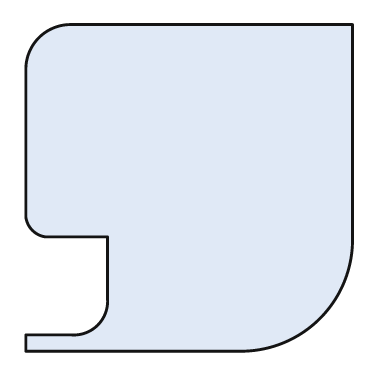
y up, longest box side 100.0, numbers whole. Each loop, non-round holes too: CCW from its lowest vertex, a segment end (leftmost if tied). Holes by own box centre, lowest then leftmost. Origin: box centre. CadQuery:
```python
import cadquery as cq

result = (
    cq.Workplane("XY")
    .moveTo(-50.0, -50.0)
    .lineTo(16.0, -50.0)
    .threePointArc((40.0, -40.0), (50.0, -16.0))
    .lineTo(50.0, 50.0)
    .lineTo(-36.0, 50.0)
    .threePointArc((-46.0, 46.0), (-50.0, 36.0))
    .lineTo(-50.0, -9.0)
    .threePointArc((-48.0, -13.0), (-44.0, -15.0))
    .lineTo(-25.0, -15.0)
    .lineTo(-25.0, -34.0)
    .threePointArc((-28.0, -42.0), (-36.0, -45.0))
    .lineTo(-50.0, -45.0)
    .close()
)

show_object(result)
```